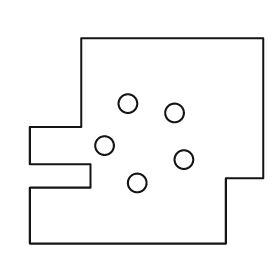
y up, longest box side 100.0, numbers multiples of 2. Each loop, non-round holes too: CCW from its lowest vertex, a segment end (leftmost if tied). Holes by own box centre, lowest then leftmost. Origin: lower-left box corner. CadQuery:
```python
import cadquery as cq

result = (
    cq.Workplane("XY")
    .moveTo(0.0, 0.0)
    .lineTo(84.0, 0.0)
    .lineTo(84.0, 28.0)
    .lineTo(100.0, 28.0)
    .lineTo(100.0, 88.0)
    .lineTo(22.0, 88.0)
    .lineTo(22.0, 50.0)
    .lineTo(0.0, 50.0)
    .lineTo(0.0, 34.0)
    .lineTo(26.0, 34.0)
    .lineTo(26.0, 24.0)
    .lineTo(0.0, 24.0)
    .close()
    .moveTo(46.0, 26.0)
    .circle(4.0)
    .moveTo(66.0, 36.0)
    .circle(4.0)
    .moveTo(32.0, 42.0)
    .circle(4.0)
    .moveTo(62.0, 56.0)
    .circle(4.0)
    .moveTo(42.0, 60.0)
    .circle(4.0)
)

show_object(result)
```